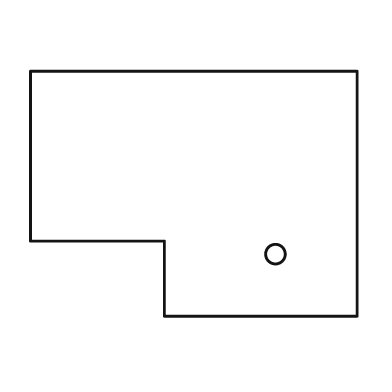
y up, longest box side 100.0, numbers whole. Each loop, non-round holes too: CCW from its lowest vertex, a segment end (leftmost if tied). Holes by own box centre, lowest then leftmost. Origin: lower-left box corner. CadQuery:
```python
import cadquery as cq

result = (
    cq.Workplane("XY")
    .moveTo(41.0, 0.0)
    .lineTo(100.0, 0.0)
    .lineTo(100.0, 75.0)
    .lineTo(0.0, 75.0)
    .lineTo(0.0, 23.0)
    .lineTo(41.0, 23.0)
    .close()
    .moveTo(75.0, 19.0)
    .circle(3.0)
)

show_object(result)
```